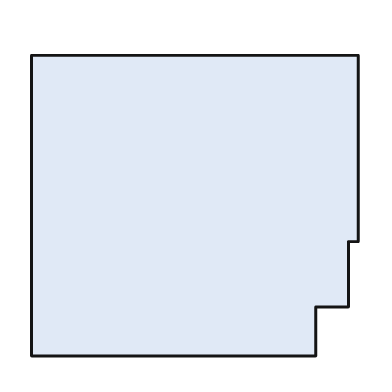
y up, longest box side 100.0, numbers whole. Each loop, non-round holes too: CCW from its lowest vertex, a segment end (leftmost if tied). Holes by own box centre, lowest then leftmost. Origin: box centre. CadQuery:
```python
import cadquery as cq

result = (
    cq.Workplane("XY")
    .moveTo(-50.0, -46.0)
    .lineTo(37.0, -46.0)
    .lineTo(37.0, -31.0)
    .lineTo(47.0, -31.0)
    .lineTo(47.0, -11.0)
    .lineTo(50.0, -11.0)
    .lineTo(50.0, 46.0)
    .lineTo(-50.0, 46.0)
    .close()
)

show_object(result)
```